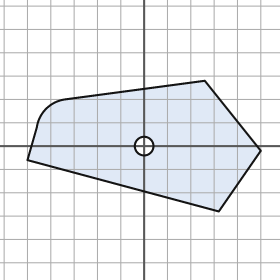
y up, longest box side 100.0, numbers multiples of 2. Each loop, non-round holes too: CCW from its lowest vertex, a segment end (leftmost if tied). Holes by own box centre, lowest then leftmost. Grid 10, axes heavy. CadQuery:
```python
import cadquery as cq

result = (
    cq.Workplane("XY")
    .moveTo(32.0, -28.0)
    .lineTo(50.0, -2.0)
    .lineTo(26.0, 28.0)
    .lineTo(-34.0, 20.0)
    .threePointArc((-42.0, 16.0), (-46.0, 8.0))
    .lineTo(-50.0, -6.0)
    .close()
    .moveTo(0.0, 0.0)
    .circle(4.0)
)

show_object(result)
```